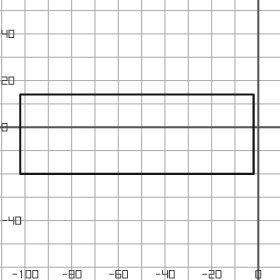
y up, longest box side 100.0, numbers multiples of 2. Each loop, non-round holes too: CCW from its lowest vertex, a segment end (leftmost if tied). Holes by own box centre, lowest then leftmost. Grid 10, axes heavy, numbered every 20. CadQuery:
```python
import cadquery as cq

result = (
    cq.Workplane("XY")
    .moveTo(-102.0, -20.0)
    .lineTo(-2.0, -20.0)
    .lineTo(-2.0, 14.0)
    .lineTo(-102.0, 14.0)
    .close()
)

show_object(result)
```